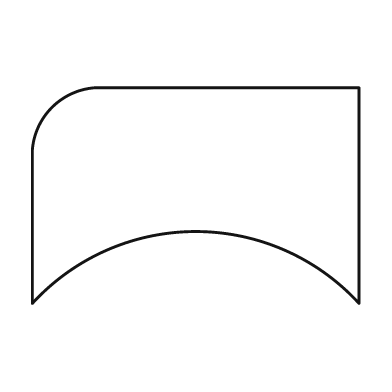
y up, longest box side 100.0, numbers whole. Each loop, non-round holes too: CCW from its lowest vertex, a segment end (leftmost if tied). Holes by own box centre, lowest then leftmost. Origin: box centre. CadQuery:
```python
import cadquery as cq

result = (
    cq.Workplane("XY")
    .moveTo(-50.0, -33.0)
    .threePointArc((0.0, -11.0), (50.0, -33.0))
    .lineTo(50.0, 33.0)
    .lineTo(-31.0, 33.0)
    .threePointArc((-44.0, 27.0), (-50.0, 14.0))
    .close()
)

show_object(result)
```